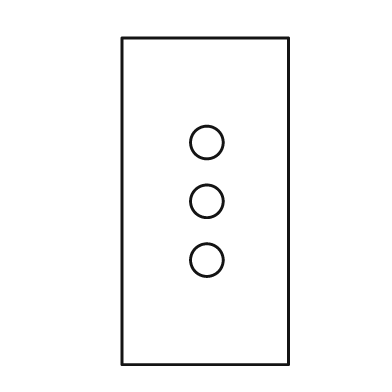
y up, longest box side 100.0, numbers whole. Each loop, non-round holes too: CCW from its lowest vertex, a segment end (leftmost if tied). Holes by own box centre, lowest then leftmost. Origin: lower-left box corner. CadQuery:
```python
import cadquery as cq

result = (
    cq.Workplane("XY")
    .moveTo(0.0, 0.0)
    .lineTo(51.0, 0.0)
    .lineTo(51.0, 100.0)
    .lineTo(0.0, 100.0)
    .close()
    .moveTo(26.0, 32.0)
    .circle(5.0)
    .moveTo(26.0, 50.0)
    .circle(5.0)
    .moveTo(26.0, 68.0)
    .circle(5.0)
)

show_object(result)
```